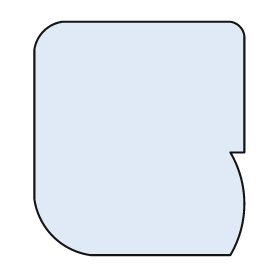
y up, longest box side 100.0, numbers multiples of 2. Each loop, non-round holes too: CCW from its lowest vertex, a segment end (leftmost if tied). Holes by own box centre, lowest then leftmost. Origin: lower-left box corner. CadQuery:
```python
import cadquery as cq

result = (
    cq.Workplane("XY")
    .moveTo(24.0, 0.0)
    .lineTo(84.0, 0.0)
    .threePointArc((90.0, 22.0), (84.0, 44.0))
    .lineTo(90.0, 44.0)
    .lineTo(90.0, 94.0)
    .threePointArc((88.0, 98.0), (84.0, 100.0))
    .lineTo(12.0, 100.0)
    .threePointArc((4.0, 96.0), (0.0, 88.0))
    .lineTo(0.0, 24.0)
    .threePointArc((8.0, 8.0), (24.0, 0.0))
    .close()
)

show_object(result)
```